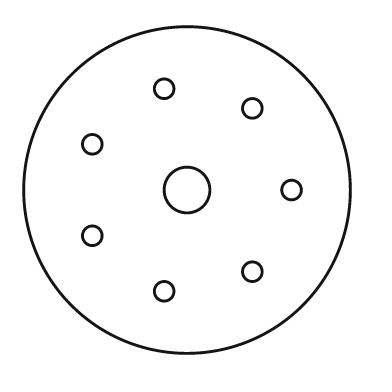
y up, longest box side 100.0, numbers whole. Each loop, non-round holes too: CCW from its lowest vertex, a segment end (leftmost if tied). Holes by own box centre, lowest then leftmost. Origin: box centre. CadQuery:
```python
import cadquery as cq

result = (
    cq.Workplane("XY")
    .moveTo(0.0, 0.0)
    .circle(50.0)
    .moveTo(-7.0, -31.0)
    .circle(3.0)
    .moveTo(20.0, -25.0)
    .circle(3.0)
    .moveTo(-29.0, -14.0)
    .circle(3.0)
    .moveTo(0.0, 0.0)
    .circle(7.0)
    .moveTo(32.0, 0.0)
    .circle(3.0)
    .moveTo(-29.0, 14.0)
    .circle(3.0)
    .moveTo(20.0, 25.0)
    .circle(3.0)
    .moveTo(-7.0, 31.0)
    .circle(3.0)
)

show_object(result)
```